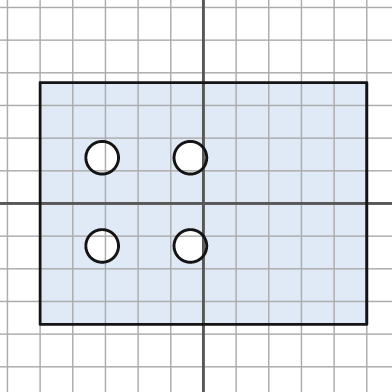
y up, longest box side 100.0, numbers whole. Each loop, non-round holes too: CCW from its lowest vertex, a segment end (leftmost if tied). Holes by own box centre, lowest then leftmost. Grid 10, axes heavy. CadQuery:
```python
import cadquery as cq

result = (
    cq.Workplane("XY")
    .moveTo(-50.0, -37.0)
    .lineTo(50.0, -37.0)
    .lineTo(50.0, 37.0)
    .lineTo(-50.0, 37.0)
    .close()
    .moveTo(-31.0, -13.0)
    .circle(5.0)
    .moveTo(-4.0, -13.0)
    .circle(5.0)
    .moveTo(-31.0, 14.0)
    .circle(5.0)
    .moveTo(-4.0, 14.0)
    .circle(5.0)
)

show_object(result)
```